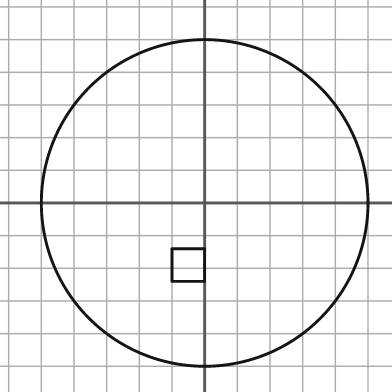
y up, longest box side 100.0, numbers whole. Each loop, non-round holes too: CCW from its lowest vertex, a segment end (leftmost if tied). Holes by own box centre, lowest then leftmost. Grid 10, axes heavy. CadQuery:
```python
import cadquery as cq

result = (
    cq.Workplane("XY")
    .moveTo(0.0, 0.0)
    .circle(50.0)
    .moveTo(-10.0, -24.0)
    .lineTo(0.0, -24.0)
    .lineTo(0.0, -14.0)
    .lineTo(-10.0, -14.0)
    .close()
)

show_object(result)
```